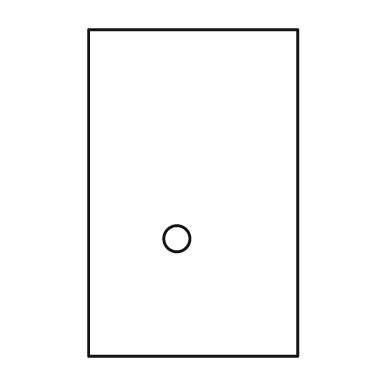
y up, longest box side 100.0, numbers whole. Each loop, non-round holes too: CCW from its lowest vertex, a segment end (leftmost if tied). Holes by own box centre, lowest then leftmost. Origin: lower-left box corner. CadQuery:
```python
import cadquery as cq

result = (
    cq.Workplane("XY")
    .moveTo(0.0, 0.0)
    .lineTo(64.0, 0.0)
    .lineTo(64.0, 100.0)
    .lineTo(0.0, 100.0)
    .close()
    .moveTo(27.0, 36.0)
    .circle(4.0)
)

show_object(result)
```